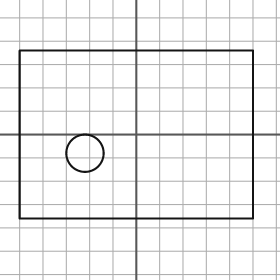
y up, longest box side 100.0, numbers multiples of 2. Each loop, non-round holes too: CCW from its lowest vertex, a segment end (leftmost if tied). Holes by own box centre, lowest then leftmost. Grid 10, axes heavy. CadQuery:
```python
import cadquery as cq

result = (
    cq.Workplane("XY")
    .moveTo(-50.0, -36.0)
    .lineTo(50.0, -36.0)
    .lineTo(50.0, 36.0)
    .lineTo(-50.0, 36.0)
    .close()
    .moveTo(-22.0, -8.0)
    .circle(8.0)
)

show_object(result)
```